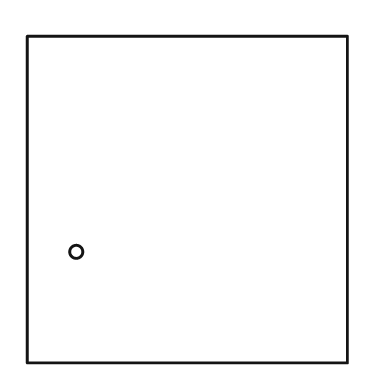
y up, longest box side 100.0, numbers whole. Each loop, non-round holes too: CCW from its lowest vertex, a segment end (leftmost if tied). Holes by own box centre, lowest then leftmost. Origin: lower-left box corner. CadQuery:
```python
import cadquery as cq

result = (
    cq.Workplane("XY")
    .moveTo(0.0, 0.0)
    .lineTo(98.0, 0.0)
    .lineTo(98.0, 100.0)
    .lineTo(0.0, 100.0)
    .close()
    .moveTo(15.0, 34.0)
    .circle(2.0)
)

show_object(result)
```